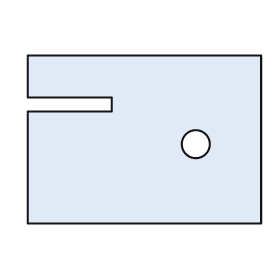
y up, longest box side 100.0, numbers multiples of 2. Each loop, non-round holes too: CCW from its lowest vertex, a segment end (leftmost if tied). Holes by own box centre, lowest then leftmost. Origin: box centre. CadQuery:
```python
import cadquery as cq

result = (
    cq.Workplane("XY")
    .moveTo(-50.0, -36.0)
    .lineTo(50.0, -36.0)
    .lineTo(50.0, 36.0)
    .lineTo(-50.0, 36.0)
    .lineTo(-50.0, 18.0)
    .lineTo(-14.0, 18.0)
    .lineTo(-14.0, 12.0)
    .lineTo(-50.0, 12.0)
    .close()
    .moveTo(22.0, -2.0)
    .circle(6.0)
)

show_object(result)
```